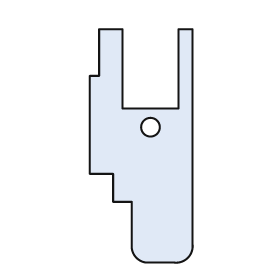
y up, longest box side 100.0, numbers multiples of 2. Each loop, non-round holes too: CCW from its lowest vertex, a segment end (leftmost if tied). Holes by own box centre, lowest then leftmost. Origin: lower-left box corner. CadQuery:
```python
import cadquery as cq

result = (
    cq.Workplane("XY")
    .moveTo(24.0, 0.0)
    .lineTo(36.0, 0.0)
    .threePointArc((42.0, 2.0), (44.0, 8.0))
    .lineTo(44.0, 100.0)
    .lineTo(38.0, 100.0)
    .lineTo(38.0, 66.0)
    .lineTo(14.0, 66.0)
    .lineTo(14.0, 100.0)
    .lineTo(4.0, 100.0)
    .lineTo(4.0, 80.0)
    .lineTo(0.0, 80.0)
    .lineTo(0.0, 38.0)
    .lineTo(10.0, 38.0)
    .lineTo(10.0, 26.0)
    .lineTo(18.0, 26.0)
    .lineTo(18.0, 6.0)
    .threePointArc((20.0, 2.0), (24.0, 0.0))
    .close()
    .moveTo(26.0, 58.0)
    .circle(4.0)
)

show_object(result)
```